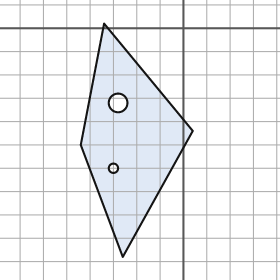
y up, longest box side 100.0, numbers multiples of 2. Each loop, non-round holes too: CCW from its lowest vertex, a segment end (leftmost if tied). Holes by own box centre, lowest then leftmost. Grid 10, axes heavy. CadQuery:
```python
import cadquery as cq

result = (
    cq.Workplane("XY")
    .moveTo(-26.0, -98.0)
    .lineTo(4.0, -44.0)
    .lineTo(-34.0, 2.0)
    .lineTo(-44.0, -50.0)
    .close()
    .moveTo(-30.0, -60.0)
    .circle(2.0)
    .moveTo(-28.0, -32.0)
    .circle(4.0)
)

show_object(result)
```